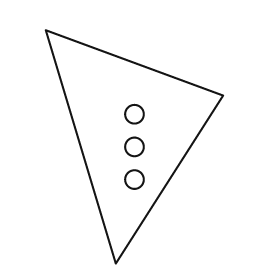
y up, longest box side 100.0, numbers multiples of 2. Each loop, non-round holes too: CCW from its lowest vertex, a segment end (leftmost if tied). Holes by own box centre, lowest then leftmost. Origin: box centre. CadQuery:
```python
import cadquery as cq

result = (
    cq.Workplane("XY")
    .moveTo(-8.0, -50.0)
    .lineTo(38.0, 22.0)
    .lineTo(-38.0, 50.0)
    .close()
    .moveTo(0.0, -14.0)
    .circle(4.0)
    .moveTo(0.0, 0.0)
    .circle(4.0)
    .moveTo(0.0, 14.0)
    .circle(4.0)
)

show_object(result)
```